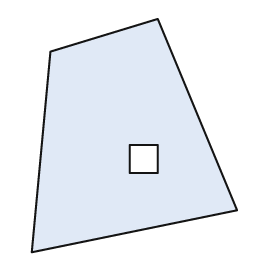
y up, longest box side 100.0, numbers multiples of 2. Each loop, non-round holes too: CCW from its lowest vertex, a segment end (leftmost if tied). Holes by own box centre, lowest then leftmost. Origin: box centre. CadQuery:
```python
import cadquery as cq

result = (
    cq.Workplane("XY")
    .moveTo(-44.0, -50.0)
    .lineTo(44.0, -32.0)
    .lineTo(10.0, 50.0)
    .lineTo(-36.0, 36.0)
    .close()
    .moveTo(-2.0, -16.0)
    .lineTo(10.0, -16.0)
    .lineTo(10.0, -4.0)
    .lineTo(-2.0, -4.0)
    .close()
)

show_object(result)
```